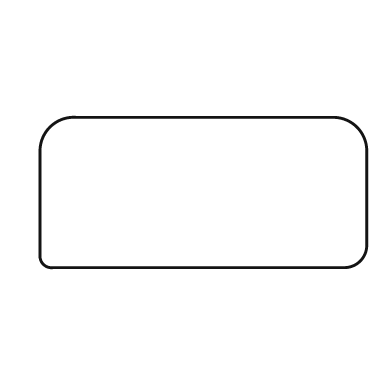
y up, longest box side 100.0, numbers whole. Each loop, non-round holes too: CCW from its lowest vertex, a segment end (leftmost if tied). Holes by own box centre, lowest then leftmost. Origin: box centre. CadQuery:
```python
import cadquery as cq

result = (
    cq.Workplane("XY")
    .moveTo(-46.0, -23.0)
    .lineTo(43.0, -23.0)
    .threePointArc((48.0, -21.0), (50.0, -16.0))
    .lineTo(50.0, 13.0)
    .threePointArc((47.0, 20.0), (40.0, 23.0))
    .lineTo(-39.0, 23.0)
    .threePointArc((-47.0, 20.0), (-50.0, 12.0))
    .lineTo(-50.0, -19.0)
    .threePointArc((-49.0, -22.0), (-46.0, -23.0))
    .close()
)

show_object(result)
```